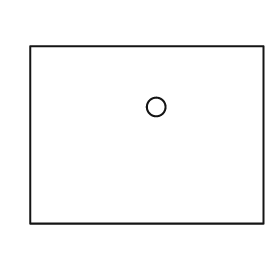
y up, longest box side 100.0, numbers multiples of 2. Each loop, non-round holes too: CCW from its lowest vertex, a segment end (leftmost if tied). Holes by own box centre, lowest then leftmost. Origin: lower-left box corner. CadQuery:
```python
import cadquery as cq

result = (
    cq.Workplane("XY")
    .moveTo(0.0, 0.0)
    .lineTo(100.0, 0.0)
    .lineTo(100.0, 76.0)
    .lineTo(0.0, 76.0)
    .close()
    .moveTo(54.0, 50.0)
    .circle(4.0)
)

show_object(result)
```